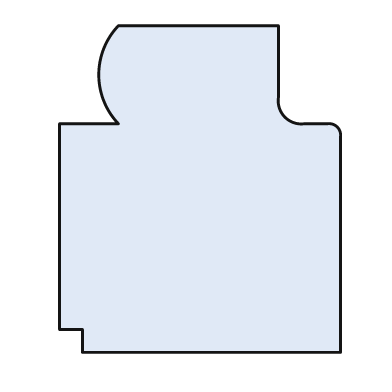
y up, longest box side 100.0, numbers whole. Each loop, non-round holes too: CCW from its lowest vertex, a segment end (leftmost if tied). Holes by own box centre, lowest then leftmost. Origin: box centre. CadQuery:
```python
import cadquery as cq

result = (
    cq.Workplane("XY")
    .moveTo(-36.0, -50.0)
    .lineTo(43.0, -50.0)
    .lineTo(43.0, 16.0)
    .threePointArc((42.0, 19.0), (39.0, 20.0))
    .lineTo(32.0, 20.0)
    .threePointArc((26.0, 22.0), (24.0, 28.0))
    .lineTo(24.0, 50.0)
    .lineTo(-25.0, 50.0)
    .threePointArc((-31.0, 35.0), (-25.0, 20.0))
    .lineTo(-43.0, 20.0)
    .lineTo(-43.0, -43.0)
    .lineTo(-36.0, -43.0)
    .close()
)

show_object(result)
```